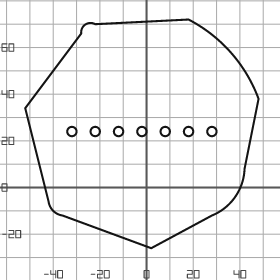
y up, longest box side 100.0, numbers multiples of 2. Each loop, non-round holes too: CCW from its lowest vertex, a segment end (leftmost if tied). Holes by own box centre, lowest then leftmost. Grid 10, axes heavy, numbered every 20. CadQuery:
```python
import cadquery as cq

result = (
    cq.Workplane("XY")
    .moveTo(2.0, -26.0)
    .lineTo(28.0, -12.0)
    .threePointArc((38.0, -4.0), (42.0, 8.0))
    .lineTo(48.0, 38.0)
    .threePointArc((36.0, 58.0), (18.0, 72.0))
    .lineTo(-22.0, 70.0)
    .threePointArc((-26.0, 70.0), (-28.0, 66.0))
    .lineTo(-52.0, 34.0)
    .lineTo(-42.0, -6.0)
    .threePointArc((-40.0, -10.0), (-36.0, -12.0))
    .close()
    .moveTo(-32.0, 24.0)
    .circle(2.0)
    .moveTo(-22.0, 24.0)
    .circle(2.0)
    .moveTo(-12.0, 24.0)
    .circle(2.0)
    .moveTo(-2.0, 24.0)
    .circle(2.0)
    .moveTo(8.0, 24.0)
    .circle(2.0)
    .moveTo(18.0, 24.0)
    .circle(2.0)
    .moveTo(28.0, 24.0)
    .circle(2.0)
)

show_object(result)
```